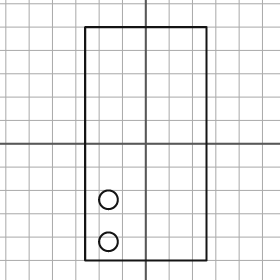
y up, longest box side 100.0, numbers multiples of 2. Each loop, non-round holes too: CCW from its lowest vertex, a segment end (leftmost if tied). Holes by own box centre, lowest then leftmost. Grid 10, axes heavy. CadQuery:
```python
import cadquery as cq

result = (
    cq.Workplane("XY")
    .moveTo(-26.0, -50.0)
    .lineTo(26.0, -50.0)
    .lineTo(26.0, 50.0)
    .lineTo(-26.0, 50.0)
    .close()
    .moveTo(-16.0, -42.0)
    .circle(4.0)
    .moveTo(-16.0, -24.0)
    .circle(4.0)
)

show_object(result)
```